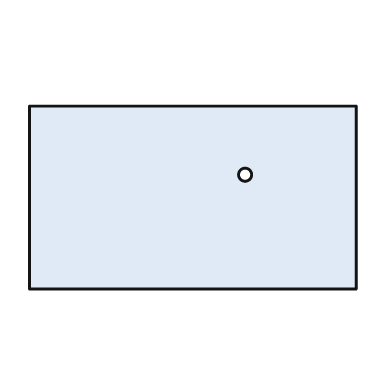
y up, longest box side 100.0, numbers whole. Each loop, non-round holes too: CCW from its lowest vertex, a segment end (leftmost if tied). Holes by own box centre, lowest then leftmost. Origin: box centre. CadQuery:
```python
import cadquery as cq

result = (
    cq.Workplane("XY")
    .moveTo(-50.0, -28.0)
    .lineTo(50.0, -28.0)
    .lineTo(50.0, 28.0)
    .lineTo(-50.0, 28.0)
    .close()
    .moveTo(16.0, 7.0)
    .circle(2.0)
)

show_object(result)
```